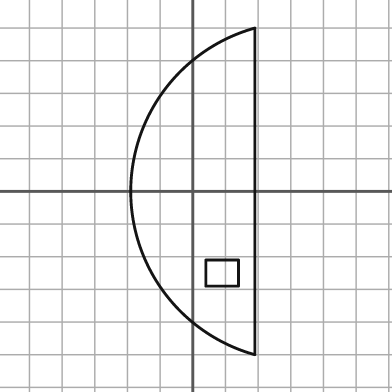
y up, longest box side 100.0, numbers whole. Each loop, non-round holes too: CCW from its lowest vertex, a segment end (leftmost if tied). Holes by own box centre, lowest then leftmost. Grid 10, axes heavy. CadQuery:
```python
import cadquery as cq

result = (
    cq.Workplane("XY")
    .moveTo(19.0, -50.0)
    .lineTo(19.0, 50.0)
    .threePointArc((-19.0, 0.0), (19.0, -50.0))
    .close()
    .moveTo(4.0, -29.0)
    .lineTo(14.0, -29.0)
    .lineTo(14.0, -21.0)
    .lineTo(4.0, -21.0)
    .close()
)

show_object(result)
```